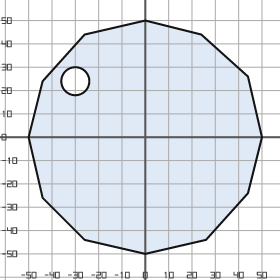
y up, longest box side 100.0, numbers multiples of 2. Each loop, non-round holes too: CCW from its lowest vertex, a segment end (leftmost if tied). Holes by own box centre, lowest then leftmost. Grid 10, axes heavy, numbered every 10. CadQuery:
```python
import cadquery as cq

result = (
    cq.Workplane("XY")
    .moveTo(0.0, -50.0)
    .lineTo(26.0, -44.0)
    .lineTo(44.0, -24.0)
    .lineTo(50.0, 0.0)
    .lineTo(44.0, 26.0)
    .lineTo(24.0, 44.0)
    .lineTo(0.0, 50.0)
    .lineTo(-26.0, 44.0)
    .lineTo(-44.0, 24.0)
    .lineTo(-50.0, 0.0)
    .lineTo(-44.0, -26.0)
    .lineTo(-26.0, -44.0)
    .close()
    .moveTo(-30.0, 24.0)
    .circle(6.0)
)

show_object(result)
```